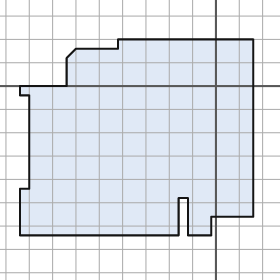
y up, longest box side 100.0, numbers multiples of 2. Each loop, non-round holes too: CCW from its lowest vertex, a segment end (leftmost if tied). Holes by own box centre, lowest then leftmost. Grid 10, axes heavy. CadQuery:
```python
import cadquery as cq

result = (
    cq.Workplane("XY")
    .moveTo(-84.0, -64.0)
    .lineTo(-16.0, -64.0)
    .lineTo(-16.0, -48.0)
    .lineTo(-12.0, -48.0)
    .lineTo(-12.0, -64.0)
    .lineTo(-2.0, -64.0)
    .lineTo(-2.0, -56.0)
    .lineTo(16.0, -56.0)
    .lineTo(16.0, 20.0)
    .lineTo(-42.0, 20.0)
    .lineTo(-42.0, 16.0)
    .lineTo(-60.0, 16.0)
    .lineTo(-64.0, 12.0)
    .lineTo(-64.0, 0.0)
    .lineTo(-84.0, 0.0)
    .lineTo(-84.0, -4.0)
    .lineTo(-80.0, -4.0)
    .lineTo(-80.0, -44.0)
    .lineTo(-84.0, -44.0)
    .close()
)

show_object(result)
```